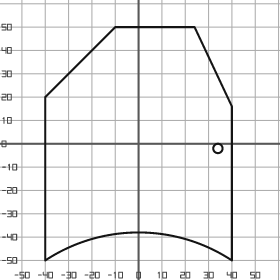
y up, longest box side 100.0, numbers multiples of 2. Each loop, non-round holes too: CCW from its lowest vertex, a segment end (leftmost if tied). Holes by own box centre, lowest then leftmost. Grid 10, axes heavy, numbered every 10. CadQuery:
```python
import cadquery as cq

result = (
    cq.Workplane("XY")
    .moveTo(-40.0, -50.0)
    .threePointArc((0.0, -38.0), (40.0, -50.0))
    .lineTo(40.0, 16.0)
    .lineTo(24.0, 50.0)
    .lineTo(-10.0, 50.0)
    .lineTo(-40.0, 20.0)
    .close()
    .moveTo(34.0, -2.0)
    .circle(2.0)
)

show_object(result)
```